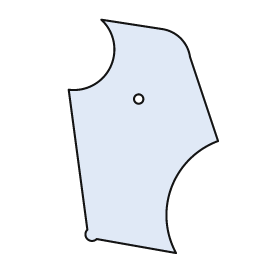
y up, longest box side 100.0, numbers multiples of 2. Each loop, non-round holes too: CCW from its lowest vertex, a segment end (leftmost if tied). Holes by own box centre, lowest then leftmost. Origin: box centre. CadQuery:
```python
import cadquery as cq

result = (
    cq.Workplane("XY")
    .moveTo(14.0, -50.0)
    .threePointArc((12.0, -22.0), (32.0, -2.0))
    .lineTo(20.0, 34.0)
    .threePointArc((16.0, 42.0), (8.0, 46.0))
    .lineTo(-18.0, 50.0)
    .threePointArc((-14.0, 30.0), (-32.0, 20.0))
    .lineTo(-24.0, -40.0)
    .threePointArc((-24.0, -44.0), (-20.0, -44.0))
    .close()
    .moveTo(-2.0, 16.0)
    .circle(2.0)
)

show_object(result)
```